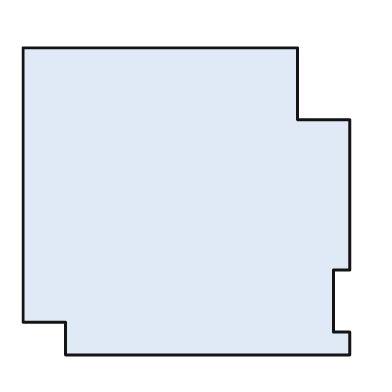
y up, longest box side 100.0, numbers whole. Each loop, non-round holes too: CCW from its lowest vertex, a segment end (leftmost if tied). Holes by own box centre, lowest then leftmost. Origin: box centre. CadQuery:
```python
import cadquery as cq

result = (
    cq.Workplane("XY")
    .moveTo(-37.0, -47.0)
    .lineTo(50.0, -47.0)
    .lineTo(50.0, -40.0)
    .lineTo(45.0, -40.0)
    .lineTo(45.0, -21.0)
    .lineTo(50.0, -21.0)
    .lineTo(50.0, 25.0)
    .lineTo(34.0, 25.0)
    .lineTo(34.0, 47.0)
    .lineTo(-50.0, 47.0)
    .lineTo(-50.0, -37.0)
    .lineTo(-37.0, -37.0)
    .close()
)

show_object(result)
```